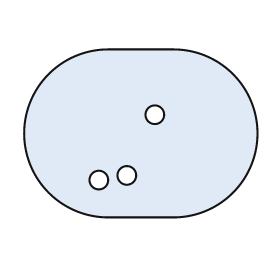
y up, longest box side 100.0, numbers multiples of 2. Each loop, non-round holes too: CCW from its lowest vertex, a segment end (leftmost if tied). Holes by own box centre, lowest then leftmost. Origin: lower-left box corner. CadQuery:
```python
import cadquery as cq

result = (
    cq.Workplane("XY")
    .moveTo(36.0, 0.0)
    .lineTo(64.0, 0.0)
    .threePointArc((100.0, 36.0), (64.0, 72.0))
    .lineTo(36.0, 72.0)
    .threePointArc((0.0, 36.0), (36.0, 0.0))
    .close()
    .moveTo(32.0, 16.0)
    .circle(4.0)
    .moveTo(44.0, 18.0)
    .circle(4.0)
    .moveTo(56.0, 44.0)
    .circle(4.0)
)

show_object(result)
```